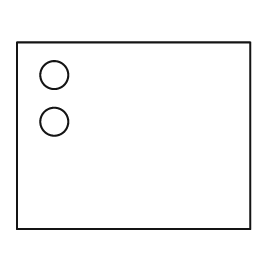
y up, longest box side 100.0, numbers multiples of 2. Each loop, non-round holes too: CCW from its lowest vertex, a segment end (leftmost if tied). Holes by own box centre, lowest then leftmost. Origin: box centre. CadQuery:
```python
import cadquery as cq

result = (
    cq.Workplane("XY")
    .moveTo(-50.0, -40.0)
    .lineTo(50.0, -40.0)
    .lineTo(50.0, 40.0)
    .lineTo(-50.0, 40.0)
    .close()
    .moveTo(-34.0, 6.0)
    .circle(6.0)
    .moveTo(-34.0, 26.0)
    .circle(6.0)
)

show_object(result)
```